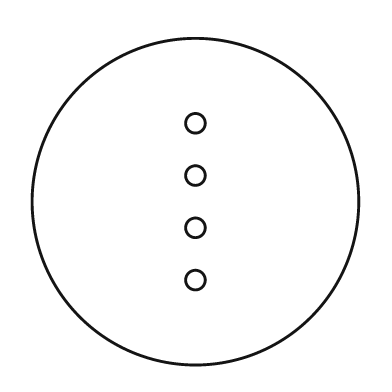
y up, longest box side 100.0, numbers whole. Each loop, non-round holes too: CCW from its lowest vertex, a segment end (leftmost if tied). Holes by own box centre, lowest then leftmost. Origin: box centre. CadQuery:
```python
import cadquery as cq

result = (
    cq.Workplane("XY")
    .moveTo(0.0, 0.0)
    .circle(50.0)
    .moveTo(0.0, -24.0)
    .circle(3.0)
    .moveTo(0.0, -8.0)
    .circle(3.0)
    .moveTo(0.0, 8.0)
    .circle(3.0)
    .moveTo(0.0, 24.0)
    .circle(3.0)
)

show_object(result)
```